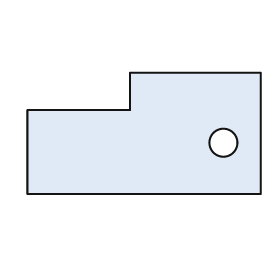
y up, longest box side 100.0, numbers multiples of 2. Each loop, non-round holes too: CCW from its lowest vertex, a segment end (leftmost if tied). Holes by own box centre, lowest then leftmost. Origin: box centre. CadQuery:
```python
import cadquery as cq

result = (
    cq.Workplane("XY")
    .moveTo(-50.0, -26.0)
    .lineTo(50.0, -26.0)
    .lineTo(50.0, 26.0)
    .lineTo(-6.0, 26.0)
    .lineTo(-6.0, 10.0)
    .lineTo(-50.0, 10.0)
    .close()
    .moveTo(34.0, -4.0)
    .circle(6.0)
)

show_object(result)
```